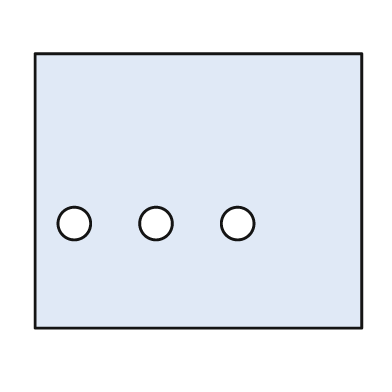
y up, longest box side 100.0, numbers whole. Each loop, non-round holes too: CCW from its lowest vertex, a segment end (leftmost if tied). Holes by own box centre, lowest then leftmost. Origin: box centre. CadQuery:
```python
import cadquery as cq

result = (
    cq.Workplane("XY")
    .moveTo(-50.0, -42.0)
    .lineTo(50.0, -42.0)
    .lineTo(50.0, 42.0)
    .lineTo(-50.0, 42.0)
    .close()
    .moveTo(-38.0, -10.0)
    .circle(5.0)
    .moveTo(-13.0, -10.0)
    .circle(5.0)
    .moveTo(12.0, -10.0)
    .circle(5.0)
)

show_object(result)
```